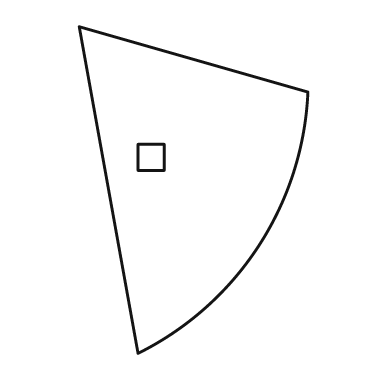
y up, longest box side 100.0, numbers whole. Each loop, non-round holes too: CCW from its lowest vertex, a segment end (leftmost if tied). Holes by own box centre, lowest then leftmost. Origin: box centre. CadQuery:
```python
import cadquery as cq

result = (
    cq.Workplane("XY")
    .moveTo(-17.0, -50.0)
    .threePointArc((20.0, -17.0), (35.0, 30.0))
    .lineTo(-35.0, 50.0)
    .close()
    .moveTo(-17.0, 6.0)
    .lineTo(-9.0, 6.0)
    .lineTo(-9.0, 14.0)
    .lineTo(-17.0, 14.0)
    .close()
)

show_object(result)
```